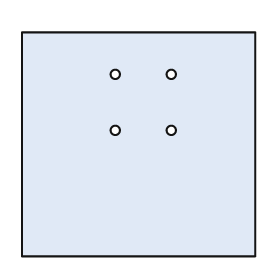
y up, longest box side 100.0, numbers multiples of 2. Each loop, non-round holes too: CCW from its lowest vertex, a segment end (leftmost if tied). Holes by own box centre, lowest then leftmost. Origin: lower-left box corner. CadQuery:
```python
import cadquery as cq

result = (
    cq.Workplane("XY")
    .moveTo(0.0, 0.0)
    .lineTo(100.0, 0.0)
    .lineTo(100.0, 96.0)
    .lineTo(0.0, 96.0)
    .close()
    .moveTo(40.0, 54.0)
    .circle(2.0)
    .moveTo(64.0, 54.0)
    .circle(2.0)
    .moveTo(40.0, 78.0)
    .circle(2.0)
    .moveTo(64.0, 78.0)
    .circle(2.0)
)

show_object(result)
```